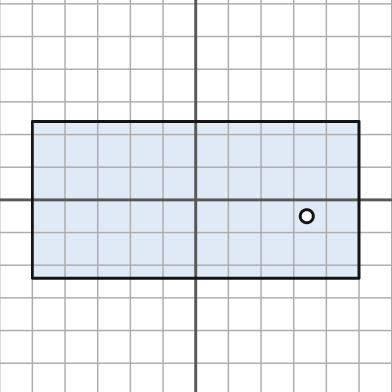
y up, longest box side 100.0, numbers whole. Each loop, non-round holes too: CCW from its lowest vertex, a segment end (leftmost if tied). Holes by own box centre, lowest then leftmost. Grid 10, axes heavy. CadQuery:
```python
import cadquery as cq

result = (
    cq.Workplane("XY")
    .moveTo(-50.0, -24.0)
    .lineTo(50.0, -24.0)
    .lineTo(50.0, 24.0)
    .lineTo(-50.0, 24.0)
    .close()
    .moveTo(34.0, -5.0)
    .circle(2.0)
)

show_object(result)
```